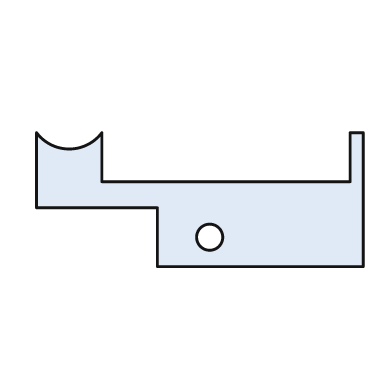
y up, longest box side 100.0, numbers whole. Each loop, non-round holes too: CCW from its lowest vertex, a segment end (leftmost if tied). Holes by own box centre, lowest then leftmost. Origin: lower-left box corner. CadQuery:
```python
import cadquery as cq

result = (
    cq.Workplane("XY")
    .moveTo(37.0, 0.0)
    .lineTo(100.0, 0.0)
    .lineTo(100.0, 41.0)
    .lineTo(96.0, 41.0)
    .lineTo(96.0, 26.0)
    .lineTo(20.0, 26.0)
    .lineTo(20.0, 41.0)
    .threePointArc((10.0, 36.0), (0.0, 41.0))
    .lineTo(0.0, 18.0)
    .lineTo(37.0, 18.0)
    .close()
    .moveTo(53.0, 9.0)
    .circle(4.0)
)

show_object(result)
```